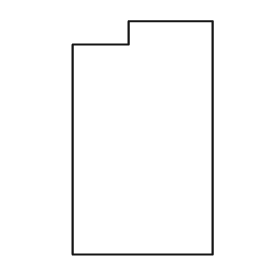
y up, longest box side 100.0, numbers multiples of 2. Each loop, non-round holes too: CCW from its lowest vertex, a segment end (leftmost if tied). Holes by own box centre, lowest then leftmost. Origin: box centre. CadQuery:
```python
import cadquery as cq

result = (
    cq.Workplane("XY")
    .moveTo(-30.0, -50.0)
    .lineTo(30.0, -50.0)
    .lineTo(30.0, 50.0)
    .lineTo(-6.0, 50.0)
    .lineTo(-6.0, 40.0)
    .lineTo(-30.0, 40.0)
    .close()
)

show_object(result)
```